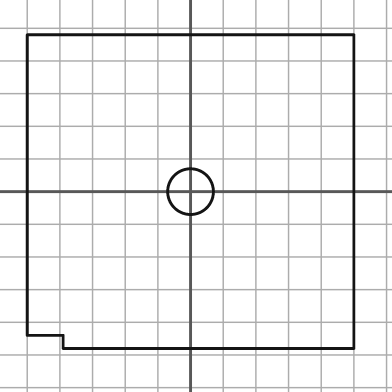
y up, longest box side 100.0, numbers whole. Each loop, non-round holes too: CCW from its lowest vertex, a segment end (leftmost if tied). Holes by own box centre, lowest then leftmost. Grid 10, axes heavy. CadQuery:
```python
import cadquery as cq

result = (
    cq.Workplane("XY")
    .moveTo(-39.0, -48.0)
    .lineTo(50.0, -48.0)
    .lineTo(50.0, 48.0)
    .lineTo(-50.0, 48.0)
    .lineTo(-50.0, -44.0)
    .lineTo(-39.0, -44.0)
    .close()
    .moveTo(0.0, 0.0)
    .circle(7.0)
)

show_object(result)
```